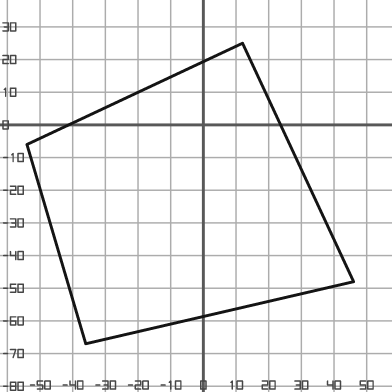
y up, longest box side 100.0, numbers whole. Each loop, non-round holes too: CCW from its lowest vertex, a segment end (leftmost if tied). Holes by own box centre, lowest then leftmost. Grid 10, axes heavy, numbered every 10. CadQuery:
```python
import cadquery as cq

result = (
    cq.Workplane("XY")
    .moveTo(-36.0, -67.0)
    .lineTo(46.0, -48.0)
    .lineTo(12.0, 25.0)
    .lineTo(-54.0, -6.0)
    .close()
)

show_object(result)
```